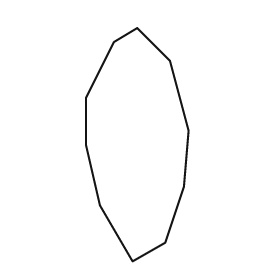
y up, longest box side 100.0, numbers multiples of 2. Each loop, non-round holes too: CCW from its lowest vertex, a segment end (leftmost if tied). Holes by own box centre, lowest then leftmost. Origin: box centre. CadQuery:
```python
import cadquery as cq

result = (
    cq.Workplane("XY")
    .moveTo(-2.0, -50.0)
    .lineTo(12.0, -42.0)
    .lineTo(20.0, -18.0)
    .lineTo(22.0, 6.0)
    .lineTo(14.0, 36.0)
    .lineTo(0.0, 50.0)
    .lineTo(-10.0, 44.0)
    .lineTo(-22.0, 20.0)
    .lineTo(-22.0, 0.0)
    .lineTo(-16.0, -26.0)
    .close()
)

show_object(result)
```